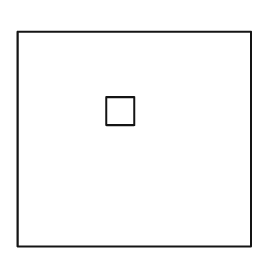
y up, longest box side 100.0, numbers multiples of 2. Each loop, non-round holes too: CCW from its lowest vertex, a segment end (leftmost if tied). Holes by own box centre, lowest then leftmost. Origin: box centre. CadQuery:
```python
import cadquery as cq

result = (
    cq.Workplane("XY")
    .moveTo(-50.0, -46.0)
    .lineTo(50.0, -46.0)
    .lineTo(50.0, 46.0)
    .lineTo(-50.0, 46.0)
    .close()
    .moveTo(-12.0, 6.0)
    .lineTo(0.0, 6.0)
    .lineTo(0.0, 18.0)
    .lineTo(-12.0, 18.0)
    .close()
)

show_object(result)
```